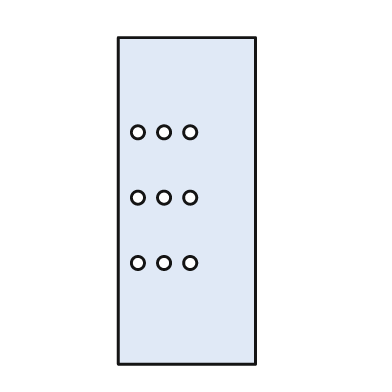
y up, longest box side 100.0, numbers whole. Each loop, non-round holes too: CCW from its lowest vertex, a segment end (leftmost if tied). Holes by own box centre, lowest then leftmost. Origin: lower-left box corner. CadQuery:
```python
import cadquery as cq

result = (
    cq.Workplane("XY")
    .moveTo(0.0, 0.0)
    .lineTo(42.0, 0.0)
    .lineTo(42.0, 100.0)
    .lineTo(0.0, 100.0)
    .close()
    .moveTo(6.0, 31.0)
    .circle(2.0)
    .moveTo(14.0, 31.0)
    .circle(2.0)
    .moveTo(22.0, 31.0)
    .circle(2.0)
    .moveTo(6.0, 51.0)
    .circle(2.0)
    .moveTo(14.0, 51.0)
    .circle(2.0)
    .moveTo(22.0, 51.0)
    .circle(2.0)
    .moveTo(6.0, 71.0)
    .circle(2.0)
    .moveTo(14.0, 71.0)
    .circle(2.0)
    .moveTo(22.0, 71.0)
    .circle(2.0)
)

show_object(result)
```